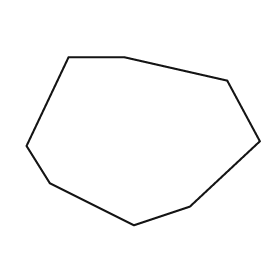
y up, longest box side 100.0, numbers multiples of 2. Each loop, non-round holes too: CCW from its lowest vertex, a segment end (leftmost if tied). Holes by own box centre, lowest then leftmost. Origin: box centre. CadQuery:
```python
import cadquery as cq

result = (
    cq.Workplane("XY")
    .moveTo(-4.0, -36.0)
    .lineTo(20.0, -28.0)
    .lineTo(50.0, 0.0)
    .lineTo(36.0, 26.0)
    .lineTo(-8.0, 36.0)
    .lineTo(-32.0, 36.0)
    .lineTo(-50.0, -2.0)
    .lineTo(-40.0, -18.0)
    .close()
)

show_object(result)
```